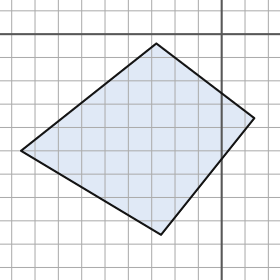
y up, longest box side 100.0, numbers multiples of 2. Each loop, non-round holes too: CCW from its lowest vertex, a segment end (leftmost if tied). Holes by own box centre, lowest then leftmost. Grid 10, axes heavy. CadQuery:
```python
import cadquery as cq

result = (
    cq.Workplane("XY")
    .moveTo(-26.0, -86.0)
    .lineTo(14.0, -36.0)
    .lineTo(-28.0, -4.0)
    .lineTo(-86.0, -50.0)
    .close()
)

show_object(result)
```